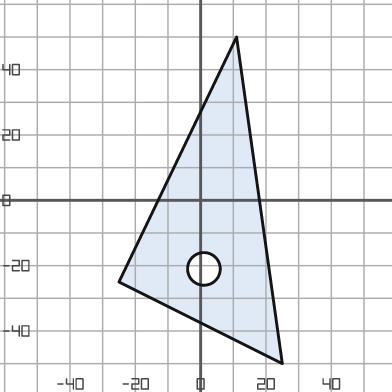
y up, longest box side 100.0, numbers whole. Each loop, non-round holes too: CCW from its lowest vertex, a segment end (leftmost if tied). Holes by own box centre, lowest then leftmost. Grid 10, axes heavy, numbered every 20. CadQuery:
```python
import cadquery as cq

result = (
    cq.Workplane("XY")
    .moveTo(25.0, -50.0)
    .lineTo(11.0, 50.0)
    .lineTo(-25.0, -25.0)
    .close()
    .moveTo(1.0, -21.0)
    .circle(5.0)
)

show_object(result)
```